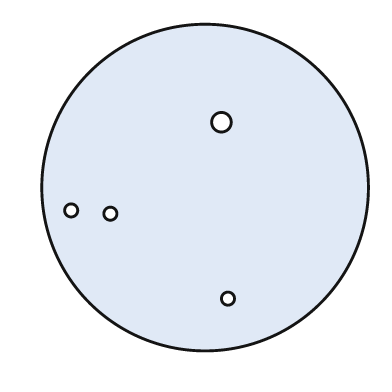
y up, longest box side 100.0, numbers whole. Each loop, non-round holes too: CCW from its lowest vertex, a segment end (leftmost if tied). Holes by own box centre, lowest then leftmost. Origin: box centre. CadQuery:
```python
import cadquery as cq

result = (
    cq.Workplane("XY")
    .moveTo(0.0, 0.0)
    .circle(50.0)
    .moveTo(7.0, -34.0)
    .circle(2.0)
    .moveTo(-29.0, -8.0)
    .circle(2.0)
    .moveTo(-41.0, -7.0)
    .circle(2.0)
    .moveTo(5.0, 20.0)
    .circle(3.0)
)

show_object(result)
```